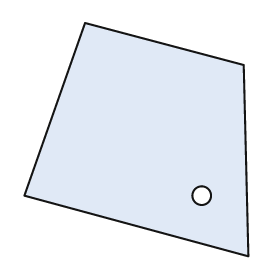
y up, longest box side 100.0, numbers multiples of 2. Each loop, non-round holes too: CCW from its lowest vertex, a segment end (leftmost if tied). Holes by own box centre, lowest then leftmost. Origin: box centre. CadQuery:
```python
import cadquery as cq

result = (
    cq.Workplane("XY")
    .moveTo(48.0, -50.0)
    .lineTo(46.0, 32.0)
    .lineTo(-22.0, 50.0)
    .lineTo(-48.0, -24.0)
    .close()
    .moveTo(28.0, -24.0)
    .circle(4.0)
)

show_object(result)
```